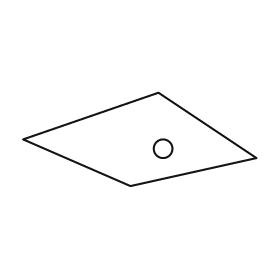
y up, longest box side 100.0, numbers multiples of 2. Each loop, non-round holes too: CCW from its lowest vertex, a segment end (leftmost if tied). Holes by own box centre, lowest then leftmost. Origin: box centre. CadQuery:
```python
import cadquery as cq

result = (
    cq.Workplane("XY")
    .moveTo(-4.0, -20.0)
    .lineTo(50.0, -8.0)
    .lineTo(8.0, 20.0)
    .lineTo(-50.0, 0.0)
    .close()
    .moveTo(10.0, -4.0)
    .circle(4.0)
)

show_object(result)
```